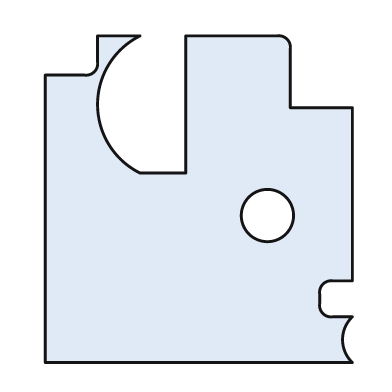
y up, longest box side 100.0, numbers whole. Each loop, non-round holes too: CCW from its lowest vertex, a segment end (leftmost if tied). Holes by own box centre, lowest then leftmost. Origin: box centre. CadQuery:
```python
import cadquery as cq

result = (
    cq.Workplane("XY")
    .moveTo(-47.0, -50.0)
    .lineTo(47.0, -50.0)
    .threePointArc((44.0, -43.0), (47.0, -36.0))
    .lineTo(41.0, -36.0)
    .threePointArc((38.0, -35.0), (37.0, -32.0))
    .lineTo(37.0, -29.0)
    .threePointArc((38.0, -26.0), (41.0, -25.0))
    .lineTo(47.0, -25.0)
    .lineTo(47.0, 28.0)
    .lineTo(28.0, 28.0)
    .lineTo(28.0, 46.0)
    .threePointArc((27.0, 49.0), (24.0, 50.0))
    .lineTo(-4.0, 50.0)
    .lineTo(-4.0, 8.0)
    .lineTo(-18.0, 8.0)
    .threePointArc((-31.0, 29.0), (-18.0, 50.0))
    .lineTo(-31.0, 50.0)
    .lineTo(-31.0, 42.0)
    .threePointArc((-32.0, 39.0), (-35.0, 38.0))
    .lineTo(-47.0, 38.0)
    .close()
    .moveTo(21.0, -5.0)
    .circle(8.0)
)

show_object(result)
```